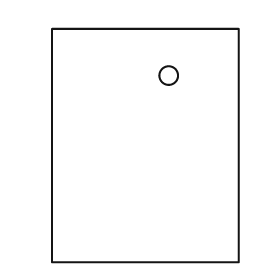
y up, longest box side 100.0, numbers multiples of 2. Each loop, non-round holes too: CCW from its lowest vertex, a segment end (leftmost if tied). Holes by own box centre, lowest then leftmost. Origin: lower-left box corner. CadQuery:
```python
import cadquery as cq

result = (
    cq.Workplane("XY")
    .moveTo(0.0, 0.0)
    .lineTo(80.0, 0.0)
    .lineTo(80.0, 100.0)
    .lineTo(0.0, 100.0)
    .close()
    .moveTo(50.0, 80.0)
    .circle(4.0)
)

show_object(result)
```